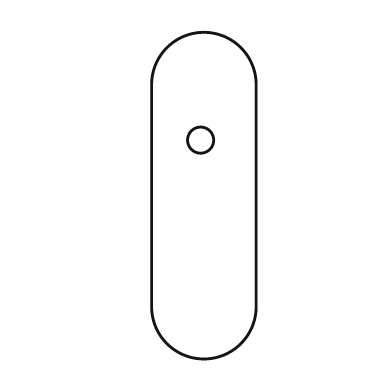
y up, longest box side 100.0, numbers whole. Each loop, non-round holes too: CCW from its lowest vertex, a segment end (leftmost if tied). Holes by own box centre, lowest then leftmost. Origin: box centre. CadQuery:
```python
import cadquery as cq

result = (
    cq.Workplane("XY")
    .moveTo(-16.0, -34.0)
    .threePointArc((0.0, -50.0), (16.0, -34.0))
    .lineTo(16.0, 34.0)
    .threePointArc((0.0, 50.0), (-16.0, 34.0))
    .close()
    .moveTo(-1.0, 17.0)
    .circle(4.0)
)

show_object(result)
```